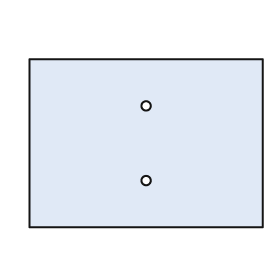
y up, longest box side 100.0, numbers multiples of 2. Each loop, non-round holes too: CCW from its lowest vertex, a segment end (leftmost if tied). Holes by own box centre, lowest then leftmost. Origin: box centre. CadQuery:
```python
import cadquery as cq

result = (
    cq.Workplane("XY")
    .moveTo(-50.0, -36.0)
    .lineTo(50.0, -36.0)
    .lineTo(50.0, 36.0)
    .lineTo(-50.0, 36.0)
    .close()
    .moveTo(0.0, -16.0)
    .circle(2.0)
    .moveTo(0.0, 16.0)
    .circle(2.0)
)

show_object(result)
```